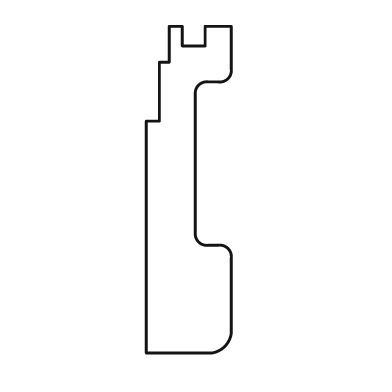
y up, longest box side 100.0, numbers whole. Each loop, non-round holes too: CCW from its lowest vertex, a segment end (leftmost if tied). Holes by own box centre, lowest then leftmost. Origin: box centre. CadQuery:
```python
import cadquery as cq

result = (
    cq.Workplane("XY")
    .moveTo(-13.0, -50.0)
    .lineTo(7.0, -50.0)
    .threePointArc((11.0, -48.0), (13.0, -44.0))
    .lineTo(13.0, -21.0)
    .threePointArc((12.0, -18.0), (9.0, -17.0))
    .lineTo(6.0, -17.0)
    .threePointArc((3.0, -16.0), (2.0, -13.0))
    .lineTo(2.0, 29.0)
    .threePointArc((3.0, 32.0), (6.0, 33.0))
    .lineTo(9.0, 33.0)
    .threePointArc((12.0, 34.0), (13.0, 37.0))
    .lineTo(13.0, 50.0)
    .lineTo(5.0, 50.0)
    .lineTo(5.0, 44.0)
    .lineTo(-2.0, 44.0)
    .lineTo(-2.0, 50.0)
    .lineTo(-6.0, 50.0)
    .lineTo(-6.0, 39.0)
    .lineTo(-9.0, 39.0)
    .lineTo(-9.0, 21.0)
    .lineTo(-13.0, 21.0)
    .close()
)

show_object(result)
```